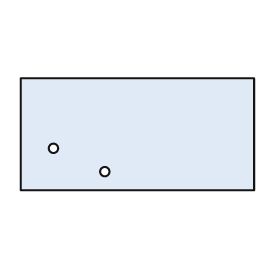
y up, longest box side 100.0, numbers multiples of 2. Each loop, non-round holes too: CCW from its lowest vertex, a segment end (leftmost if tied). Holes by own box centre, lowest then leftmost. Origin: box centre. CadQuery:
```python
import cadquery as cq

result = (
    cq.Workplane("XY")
    .moveTo(-50.0, -24.0)
    .lineTo(50.0, -24.0)
    .lineTo(50.0, 24.0)
    .lineTo(-50.0, 24.0)
    .close()
    .moveTo(-14.0, -16.0)
    .circle(2.0)
    .moveTo(-36.0, -6.0)
    .circle(2.0)
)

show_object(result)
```